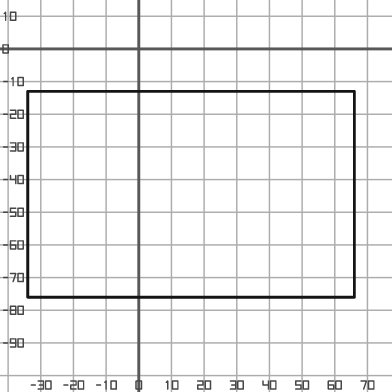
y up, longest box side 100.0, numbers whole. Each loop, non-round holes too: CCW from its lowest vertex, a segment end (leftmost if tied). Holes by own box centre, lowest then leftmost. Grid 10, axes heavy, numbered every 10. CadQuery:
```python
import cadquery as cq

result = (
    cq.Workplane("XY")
    .moveTo(-34.0, -76.0)
    .lineTo(66.0, -76.0)
    .lineTo(66.0, -13.0)
    .lineTo(-34.0, -13.0)
    .close()
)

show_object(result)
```